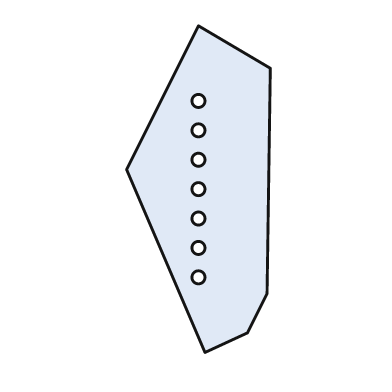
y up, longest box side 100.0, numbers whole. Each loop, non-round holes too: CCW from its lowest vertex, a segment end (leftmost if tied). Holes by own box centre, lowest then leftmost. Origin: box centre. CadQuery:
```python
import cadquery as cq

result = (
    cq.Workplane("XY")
    .moveTo(2.0, -50.0)
    .lineTo(15.0, -44.0)
    .lineTo(21.0, -32.0)
    .lineTo(22.0, 37.0)
    .lineTo(0.0, 50.0)
    .lineTo(-22.0, 6.0)
    .close()
    .moveTo(0.0, -27.0)
    .circle(2.0)
    .moveTo(0.0, -18.0)
    .circle(2.0)
    .moveTo(0.0, -9.0)
    .circle(2.0)
    .moveTo(0.0, 0.0)
    .circle(2.0)
    .moveTo(0.0, 9.0)
    .circle(2.0)
    .moveTo(0.0, 18.0)
    .circle(2.0)
    .moveTo(0.0, 27.0)
    .circle(2.0)
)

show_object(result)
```